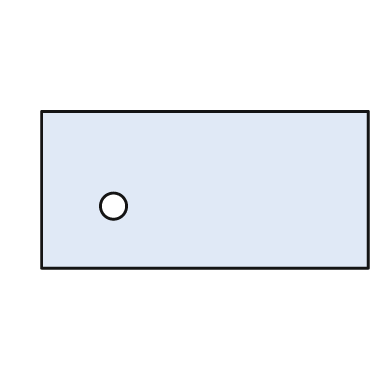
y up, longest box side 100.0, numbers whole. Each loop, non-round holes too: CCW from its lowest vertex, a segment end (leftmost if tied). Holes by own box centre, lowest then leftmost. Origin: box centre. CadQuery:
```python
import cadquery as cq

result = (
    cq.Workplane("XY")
    .moveTo(-50.0, -24.0)
    .lineTo(50.0, -24.0)
    .lineTo(50.0, 24.0)
    .lineTo(-50.0, 24.0)
    .close()
    .moveTo(-28.0, -5.0)
    .circle(4.0)
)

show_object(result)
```